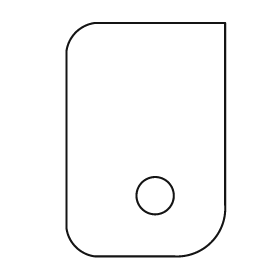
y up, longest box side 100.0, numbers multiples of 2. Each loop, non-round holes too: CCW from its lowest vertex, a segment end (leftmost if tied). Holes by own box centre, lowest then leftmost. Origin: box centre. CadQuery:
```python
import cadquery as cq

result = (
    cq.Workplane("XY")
    .moveTo(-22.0, -50.0)
    .lineTo(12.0, -50.0)
    .threePointArc((28.0, -44.0), (34.0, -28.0))
    .lineTo(34.0, 50.0)
    .lineTo(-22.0, 50.0)
    .threePointArc((-30.0, 46.0), (-34.0, 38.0))
    .lineTo(-34.0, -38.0)
    .threePointArc((-30.0, -46.0), (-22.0, -50.0))
    .close()
    .moveTo(4.0, -24.0)
    .circle(8.0)
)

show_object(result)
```